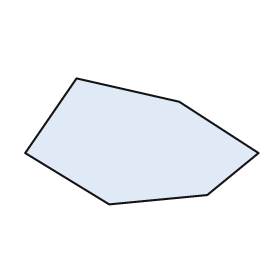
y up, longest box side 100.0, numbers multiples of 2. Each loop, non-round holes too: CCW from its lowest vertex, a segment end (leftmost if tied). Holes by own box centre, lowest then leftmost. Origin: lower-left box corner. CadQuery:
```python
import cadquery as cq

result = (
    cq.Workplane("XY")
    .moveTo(36.0, 0.0)
    .lineTo(78.0, 4.0)
    .lineTo(100.0, 22.0)
    .lineTo(66.0, 44.0)
    .lineTo(22.0, 54.0)
    .lineTo(0.0, 22.0)
    .close()
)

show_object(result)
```